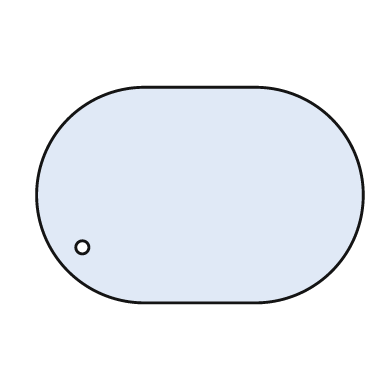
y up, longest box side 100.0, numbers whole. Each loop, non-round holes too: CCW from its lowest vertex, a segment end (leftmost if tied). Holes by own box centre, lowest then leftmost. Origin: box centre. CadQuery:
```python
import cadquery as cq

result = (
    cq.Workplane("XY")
    .moveTo(-17.0, -33.0)
    .lineTo(17.0, -33.0)
    .threePointArc((50.0, 0.0), (17.0, 33.0))
    .lineTo(-17.0, 33.0)
    .threePointArc((-50.0, 0.0), (-17.0, -33.0))
    .close()
    .moveTo(-36.0, -16.0)
    .circle(2.0)
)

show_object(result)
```